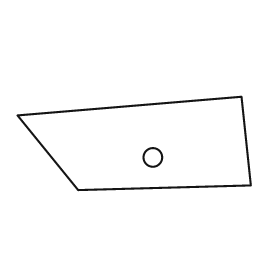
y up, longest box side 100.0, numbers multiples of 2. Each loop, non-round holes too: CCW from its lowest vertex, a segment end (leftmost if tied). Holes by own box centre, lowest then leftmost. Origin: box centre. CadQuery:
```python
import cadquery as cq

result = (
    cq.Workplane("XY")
    .moveTo(-24.0, -20.0)
    .lineTo(50.0, -18.0)
    .lineTo(46.0, 20.0)
    .lineTo(-50.0, 12.0)
    .close()
    .moveTo(8.0, -6.0)
    .circle(4.0)
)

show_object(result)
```